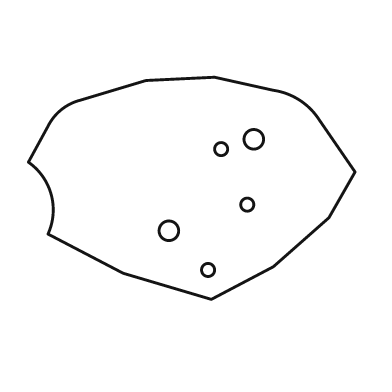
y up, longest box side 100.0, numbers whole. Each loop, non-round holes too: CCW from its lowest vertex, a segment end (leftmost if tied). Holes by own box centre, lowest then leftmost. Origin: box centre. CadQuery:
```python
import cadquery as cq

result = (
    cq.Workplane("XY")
    .moveTo(6.0, -34.0)
    .lineTo(25.0, -24.0)
    .lineTo(42.0, -9.0)
    .lineTo(50.0, 5.0)
    .lineTo(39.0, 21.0)
    .threePointArc((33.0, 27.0), (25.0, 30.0))
    .lineTo(7.0, 34.0)
    .lineTo(-14.0, 33.0)
    .lineTo(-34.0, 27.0)
    .threePointArc((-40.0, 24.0), (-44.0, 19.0))
    .lineTo(-50.0, 8.0)
    .threePointArc((-43.0, -2.0), (-44.0, -14.0))
    .lineTo(-21.0, -26.0)
    .close()
    .moveTo(5.0, -25.0)
    .circle(2.0)
    .moveTo(-7.0, -13.0)
    .circle(3.0)
    .moveTo(17.0, -5.0)
    .circle(2.0)
    .moveTo(9.0, 12.0)
    .circle(2.0)
    .moveTo(19.0, 15.0)
    .circle(3.0)
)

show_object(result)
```